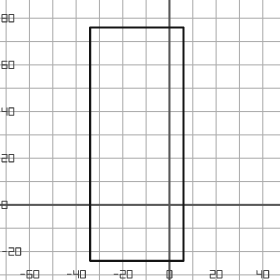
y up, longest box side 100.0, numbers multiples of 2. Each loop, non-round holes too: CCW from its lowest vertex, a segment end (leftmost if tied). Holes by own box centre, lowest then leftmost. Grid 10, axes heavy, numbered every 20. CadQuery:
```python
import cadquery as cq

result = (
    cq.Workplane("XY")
    .moveTo(-34.0, -24.0)
    .lineTo(6.0, -24.0)
    .lineTo(6.0, 76.0)
    .lineTo(-34.0, 76.0)
    .close()
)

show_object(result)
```